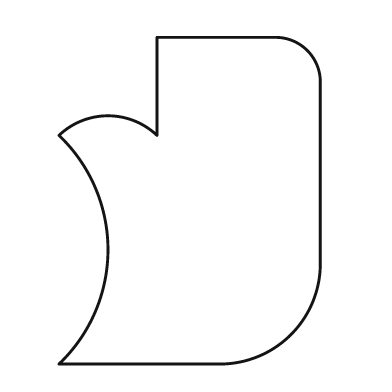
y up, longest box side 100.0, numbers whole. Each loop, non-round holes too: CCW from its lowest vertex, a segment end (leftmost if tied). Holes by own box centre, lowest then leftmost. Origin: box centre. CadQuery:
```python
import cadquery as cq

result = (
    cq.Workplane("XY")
    .moveTo(-40.0, -50.0)
    .lineTo(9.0, -50.0)
    .threePointArc((31.0, -41.0), (40.0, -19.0))
    .lineTo(40.0, 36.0)
    .threePointArc((36.0, 46.0), (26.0, 50.0))
    .lineTo(-10.0, 50.0)
    .lineTo(-10.0, 20.0)
    .threePointArc((-25.0, 26.0), (-40.0, 20.0))
    .threePointArc((-25.0, -15.0), (-40.0, -50.0))
    .close()
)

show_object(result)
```